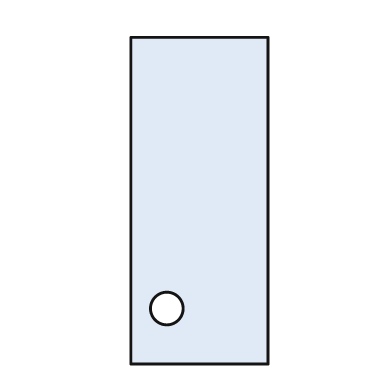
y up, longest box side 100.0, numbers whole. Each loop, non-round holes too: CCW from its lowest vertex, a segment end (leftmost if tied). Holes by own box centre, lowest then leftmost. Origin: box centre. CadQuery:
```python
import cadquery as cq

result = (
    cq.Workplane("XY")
    .moveTo(-21.0, -50.0)
    .lineTo(21.0, -50.0)
    .lineTo(21.0, 50.0)
    .lineTo(-21.0, 50.0)
    .close()
    .moveTo(-10.0, -33.0)
    .circle(5.0)
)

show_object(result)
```